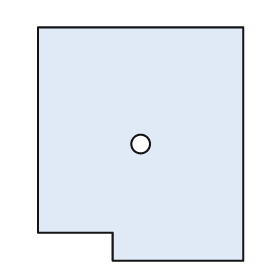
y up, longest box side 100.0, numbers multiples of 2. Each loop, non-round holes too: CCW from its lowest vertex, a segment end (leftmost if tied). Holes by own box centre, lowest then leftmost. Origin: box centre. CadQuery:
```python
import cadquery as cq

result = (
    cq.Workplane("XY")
    .moveTo(-12.0, -50.0)
    .lineTo(44.0, -50.0)
    .lineTo(44.0, 50.0)
    .lineTo(-44.0, 50.0)
    .lineTo(-44.0, -38.0)
    .lineTo(-12.0, -38.0)
    .close()
    .moveTo(0.0, 0.0)
    .circle(4.0)
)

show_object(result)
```